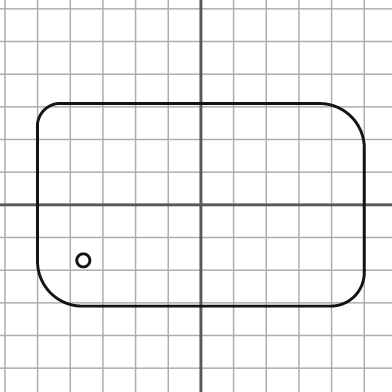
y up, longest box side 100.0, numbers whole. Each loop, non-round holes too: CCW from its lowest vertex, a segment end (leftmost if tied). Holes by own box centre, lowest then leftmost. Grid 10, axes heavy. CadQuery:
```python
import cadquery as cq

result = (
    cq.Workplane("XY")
    .moveTo(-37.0, -31.0)
    .lineTo(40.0, -31.0)
    .threePointArc((47.0, -28.0), (50.0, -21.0))
    .lineTo(50.0, 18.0)
    .threePointArc((46.0, 27.0), (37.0, 31.0))
    .lineTo(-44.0, 31.0)
    .threePointArc((-48.0, 29.0), (-50.0, 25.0))
    .lineTo(-50.0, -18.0)
    .threePointArc((-46.0, -27.0), (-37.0, -31.0))
    .close()
    .moveTo(-36.0, -17.0)
    .circle(2.0)
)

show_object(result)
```